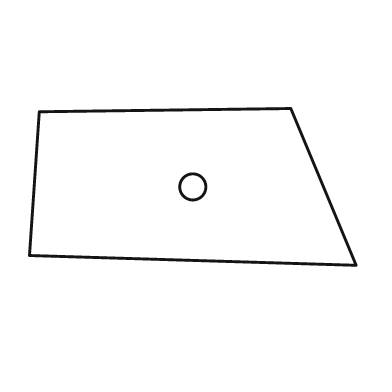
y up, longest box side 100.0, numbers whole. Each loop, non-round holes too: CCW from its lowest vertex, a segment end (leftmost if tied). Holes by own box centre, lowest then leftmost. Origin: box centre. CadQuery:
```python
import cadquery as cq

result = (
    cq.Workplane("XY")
    .moveTo(50.0, -24.0)
    .lineTo(30.0, 24.0)
    .lineTo(-47.0, 23.0)
    .lineTo(-50.0, -21.0)
    .close()
    .moveTo(0.0, 0.0)
    .circle(4.0)
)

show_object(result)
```